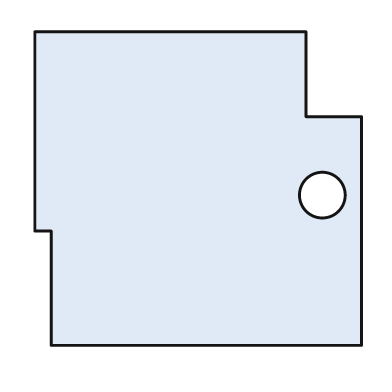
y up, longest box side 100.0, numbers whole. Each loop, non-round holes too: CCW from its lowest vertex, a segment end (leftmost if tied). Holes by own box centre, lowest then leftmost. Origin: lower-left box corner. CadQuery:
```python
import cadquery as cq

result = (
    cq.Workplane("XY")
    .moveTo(5.0, 0.0)
    .lineTo(100.0, 0.0)
    .lineTo(100.0, 70.0)
    .lineTo(83.0, 70.0)
    .lineTo(83.0, 96.0)
    .lineTo(0.0, 96.0)
    .lineTo(0.0, 35.0)
    .lineTo(5.0, 35.0)
    .close()
    .moveTo(88.0, 46.0)
    .circle(7.0)
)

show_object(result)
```